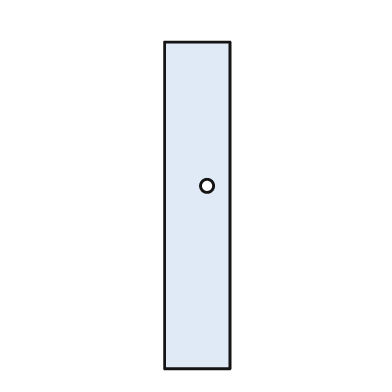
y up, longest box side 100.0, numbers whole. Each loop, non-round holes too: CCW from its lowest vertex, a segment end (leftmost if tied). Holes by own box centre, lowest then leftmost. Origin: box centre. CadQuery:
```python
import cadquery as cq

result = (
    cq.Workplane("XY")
    .moveTo(-10.0, -50.0)
    .lineTo(10.0, -50.0)
    .lineTo(10.0, 50.0)
    .lineTo(-10.0, 50.0)
    .close()
    .moveTo(3.0, 6.0)
    .circle(2.0)
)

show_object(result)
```